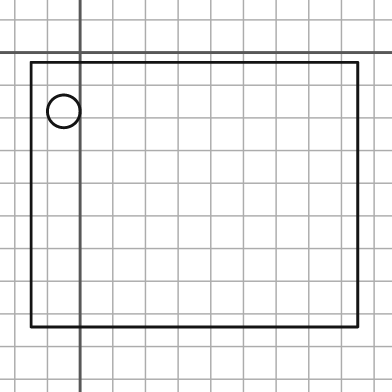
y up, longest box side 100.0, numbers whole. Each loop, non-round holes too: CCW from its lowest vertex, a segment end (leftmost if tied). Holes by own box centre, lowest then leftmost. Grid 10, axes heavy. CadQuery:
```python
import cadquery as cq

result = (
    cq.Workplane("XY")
    .moveTo(-15.0, -84.0)
    .lineTo(85.0, -84.0)
    .lineTo(85.0, -3.0)
    .lineTo(-15.0, -3.0)
    .close()
    .moveTo(-5.0, -18.0)
    .circle(5.0)
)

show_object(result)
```